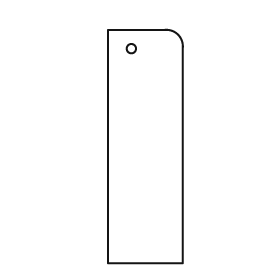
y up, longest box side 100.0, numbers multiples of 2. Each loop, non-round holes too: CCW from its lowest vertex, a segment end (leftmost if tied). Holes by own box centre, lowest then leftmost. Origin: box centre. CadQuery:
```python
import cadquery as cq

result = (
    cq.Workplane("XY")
    .moveTo(-16.0, -50.0)
    .lineTo(16.0, -50.0)
    .lineTo(16.0, 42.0)
    .threePointArc((14.0, 48.0), (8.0, 50.0))
    .lineTo(-16.0, 50.0)
    .close()
    .moveTo(-6.0, 42.0)
    .circle(2.0)
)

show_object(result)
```